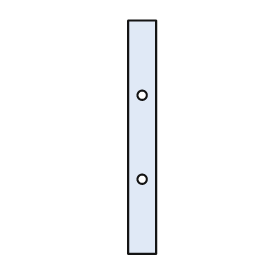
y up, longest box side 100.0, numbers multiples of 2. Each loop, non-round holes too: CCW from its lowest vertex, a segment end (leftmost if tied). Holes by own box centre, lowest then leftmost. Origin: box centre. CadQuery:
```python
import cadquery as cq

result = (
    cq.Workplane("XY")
    .moveTo(-6.0, -50.0)
    .lineTo(6.0, -50.0)
    .lineTo(6.0, 50.0)
    .lineTo(-6.0, 50.0)
    .close()
    .moveTo(0.0, -18.0)
    .circle(2.0)
    .moveTo(0.0, 18.0)
    .circle(2.0)
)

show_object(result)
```